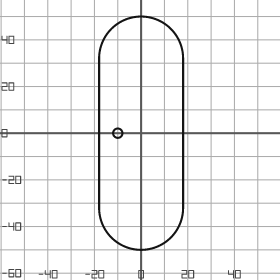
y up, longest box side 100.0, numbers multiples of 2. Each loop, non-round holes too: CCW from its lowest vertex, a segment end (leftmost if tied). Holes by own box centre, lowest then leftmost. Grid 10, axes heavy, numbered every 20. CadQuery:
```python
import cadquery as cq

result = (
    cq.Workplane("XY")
    .moveTo(-18.0, -32.0)
    .threePointArc((0.0, -50.0), (18.0, -32.0))
    .lineTo(18.0, 32.0)
    .threePointArc((0.0, 50.0), (-18.0, 32.0))
    .close()
    .moveTo(-10.0, 0.0)
    .circle(2.0)
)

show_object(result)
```